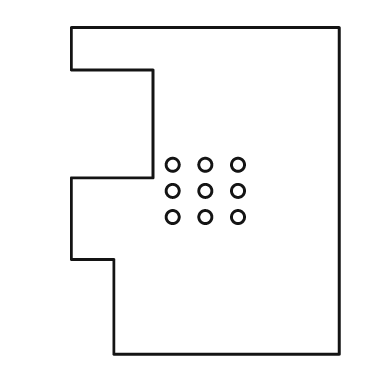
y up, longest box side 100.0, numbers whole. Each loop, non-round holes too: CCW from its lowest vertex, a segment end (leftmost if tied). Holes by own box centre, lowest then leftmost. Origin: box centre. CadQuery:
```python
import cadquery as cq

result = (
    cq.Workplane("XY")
    .moveTo(-28.0, -50.0)
    .lineTo(41.0, -50.0)
    .lineTo(41.0, 50.0)
    .lineTo(-41.0, 50.0)
    .lineTo(-41.0, 37.0)
    .lineTo(-16.0, 37.0)
    .lineTo(-16.0, 4.0)
    .lineTo(-41.0, 4.0)
    .lineTo(-41.0, -21.0)
    .lineTo(-28.0, -21.0)
    .close()
    .moveTo(-10.0, -8.0)
    .circle(2.0)
    .moveTo(0.0, -8.0)
    .circle(2.0)
    .moveTo(10.0, -8.0)
    .circle(2.0)
    .moveTo(-10.0, 0.0)
    .circle(2.0)
    .moveTo(0.0, 0.0)
    .circle(2.0)
    .moveTo(10.0, 0.0)
    .circle(2.0)
    .moveTo(-10.0, 8.0)
    .circle(2.0)
    .moveTo(0.0, 8.0)
    .circle(2.0)
    .moveTo(10.0, 8.0)
    .circle(2.0)
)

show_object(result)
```